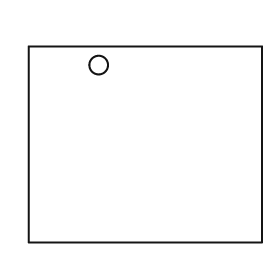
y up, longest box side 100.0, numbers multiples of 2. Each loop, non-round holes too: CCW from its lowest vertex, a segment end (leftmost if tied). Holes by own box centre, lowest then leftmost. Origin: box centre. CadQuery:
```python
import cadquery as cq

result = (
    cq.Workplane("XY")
    .moveTo(-50.0, -42.0)
    .lineTo(50.0, -42.0)
    .lineTo(50.0, 42.0)
    .lineTo(-50.0, 42.0)
    .close()
    .moveTo(-20.0, 34.0)
    .circle(4.0)
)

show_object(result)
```